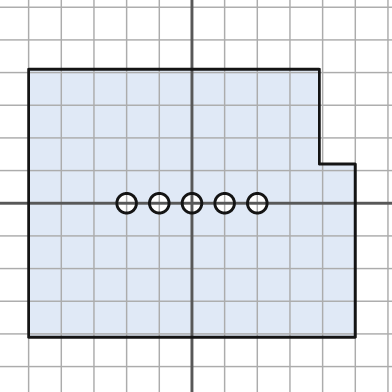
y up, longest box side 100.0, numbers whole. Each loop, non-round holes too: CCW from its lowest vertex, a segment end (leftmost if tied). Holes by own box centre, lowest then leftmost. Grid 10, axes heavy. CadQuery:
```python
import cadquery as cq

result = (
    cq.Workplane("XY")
    .moveTo(-50.0, -41.0)
    .lineTo(50.0, -41.0)
    .lineTo(50.0, 12.0)
    .lineTo(39.0, 12.0)
    .lineTo(39.0, 41.0)
    .lineTo(-50.0, 41.0)
    .close()
    .moveTo(-20.0, 0.0)
    .circle(3.0)
    .moveTo(-10.0, 0.0)
    .circle(3.0)
    .moveTo(0.0, 0.0)
    .circle(3.0)
    .moveTo(10.0, 0.0)
    .circle(3.0)
    .moveTo(20.0, 0.0)
    .circle(3.0)
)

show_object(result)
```